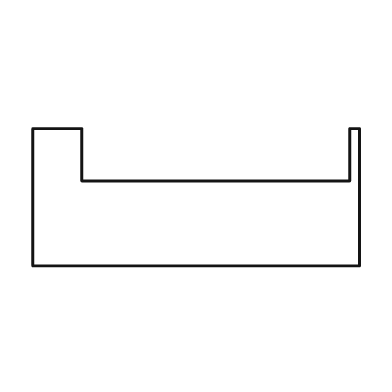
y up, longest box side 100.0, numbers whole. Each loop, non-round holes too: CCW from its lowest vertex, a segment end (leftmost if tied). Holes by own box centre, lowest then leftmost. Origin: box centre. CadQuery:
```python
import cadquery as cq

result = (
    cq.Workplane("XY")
    .moveTo(-50.0, -21.0)
    .lineTo(50.0, -21.0)
    .lineTo(50.0, 21.0)
    .lineTo(47.0, 21.0)
    .lineTo(47.0, 5.0)
    .lineTo(-35.0, 5.0)
    .lineTo(-35.0, 21.0)
    .lineTo(-50.0, 21.0)
    .close()
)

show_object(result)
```